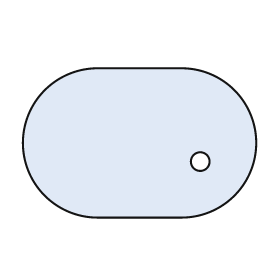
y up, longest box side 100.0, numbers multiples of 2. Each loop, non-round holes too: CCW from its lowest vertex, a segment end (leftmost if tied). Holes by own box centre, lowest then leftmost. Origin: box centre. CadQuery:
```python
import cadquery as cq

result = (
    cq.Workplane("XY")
    .moveTo(-18.0, -32.0)
    .lineTo(18.0, -32.0)
    .threePointArc((50.0, 0.0), (18.0, 32.0))
    .lineTo(-18.0, 32.0)
    .threePointArc((-50.0, 0.0), (-18.0, -32.0))
    .close()
    .moveTo(26.0, -8.0)
    .circle(4.0)
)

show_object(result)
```